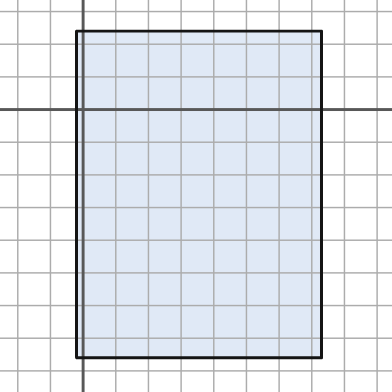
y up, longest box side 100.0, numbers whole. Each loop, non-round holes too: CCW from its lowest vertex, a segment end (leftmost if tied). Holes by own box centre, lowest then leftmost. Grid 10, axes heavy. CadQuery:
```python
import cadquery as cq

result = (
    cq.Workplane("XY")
    .moveTo(-2.0, -76.0)
    .lineTo(73.0, -76.0)
    .lineTo(73.0, 24.0)
    .lineTo(-2.0, 24.0)
    .close()
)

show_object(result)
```